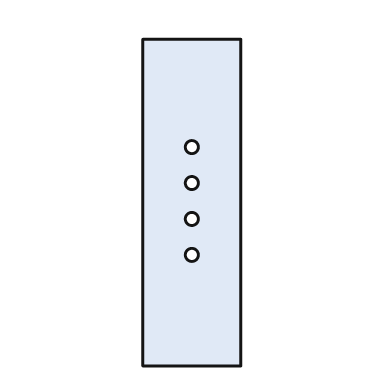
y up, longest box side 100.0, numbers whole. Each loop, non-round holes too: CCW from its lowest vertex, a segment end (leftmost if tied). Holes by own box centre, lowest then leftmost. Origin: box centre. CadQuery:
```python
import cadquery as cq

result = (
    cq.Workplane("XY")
    .moveTo(-15.0, -50.0)
    .lineTo(15.0, -50.0)
    .lineTo(15.0, 50.0)
    .lineTo(-15.0, 50.0)
    .close()
    .moveTo(0.0, -16.0)
    .circle(2.0)
    .moveTo(0.0, -5.0)
    .circle(2.0)
    .moveTo(0.0, 6.0)
    .circle(2.0)
    .moveTo(0.0, 17.0)
    .circle(2.0)
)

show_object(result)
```